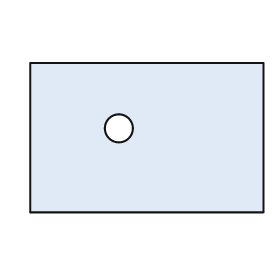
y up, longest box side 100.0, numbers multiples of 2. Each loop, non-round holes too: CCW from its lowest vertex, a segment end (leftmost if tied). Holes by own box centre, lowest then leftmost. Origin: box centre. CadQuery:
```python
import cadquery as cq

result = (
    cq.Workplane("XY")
    .moveTo(-50.0, -32.0)
    .lineTo(50.0, -32.0)
    .lineTo(50.0, 32.0)
    .lineTo(-50.0, 32.0)
    .close()
    .moveTo(-12.0, 4.0)
    .circle(6.0)
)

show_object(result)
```